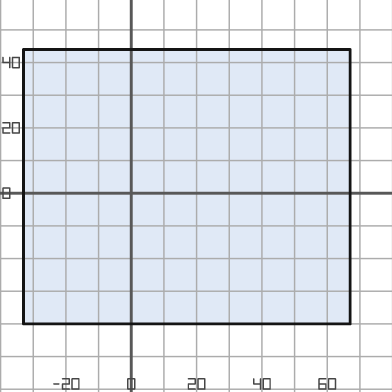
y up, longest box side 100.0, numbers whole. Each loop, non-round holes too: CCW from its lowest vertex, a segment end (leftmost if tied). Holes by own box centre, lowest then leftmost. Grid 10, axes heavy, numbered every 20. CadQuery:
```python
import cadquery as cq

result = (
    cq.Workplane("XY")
    .moveTo(-33.0, -40.0)
    .lineTo(67.0, -40.0)
    .lineTo(67.0, 44.0)
    .lineTo(-33.0, 44.0)
    .close()
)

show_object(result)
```